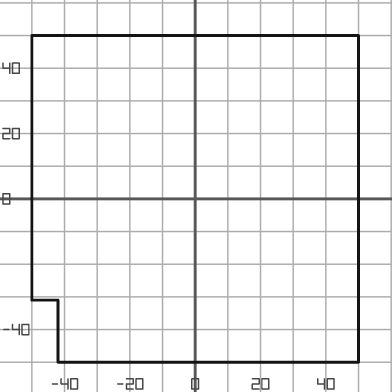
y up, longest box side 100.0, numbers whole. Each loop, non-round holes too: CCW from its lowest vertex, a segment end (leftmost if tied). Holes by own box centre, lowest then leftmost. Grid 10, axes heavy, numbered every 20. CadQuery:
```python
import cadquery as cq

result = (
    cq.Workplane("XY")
    .moveTo(-42.0, -50.0)
    .lineTo(50.0, -50.0)
    .lineTo(50.0, 50.0)
    .lineTo(-50.0, 50.0)
    .lineTo(-50.0, -31.0)
    .lineTo(-42.0, -31.0)
    .close()
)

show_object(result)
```